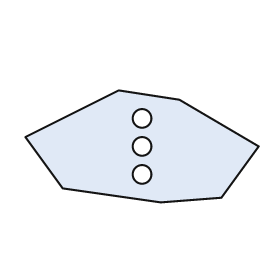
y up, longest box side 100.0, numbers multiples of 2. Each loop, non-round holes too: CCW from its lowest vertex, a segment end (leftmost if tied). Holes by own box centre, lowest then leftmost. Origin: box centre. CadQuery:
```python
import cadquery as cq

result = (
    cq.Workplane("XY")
    .moveTo(8.0, -24.0)
    .lineTo(34.0, -22.0)
    .lineTo(50.0, 0.0)
    .lineTo(16.0, 20.0)
    .lineTo(-10.0, 24.0)
    .lineTo(-50.0, 4.0)
    .lineTo(-34.0, -18.0)
    .close()
    .moveTo(0.0, -12.0)
    .circle(4.0)
    .moveTo(0.0, 0.0)
    .circle(4.0)
    .moveTo(0.0, 12.0)
    .circle(4.0)
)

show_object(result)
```